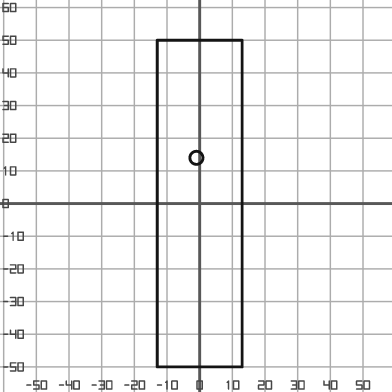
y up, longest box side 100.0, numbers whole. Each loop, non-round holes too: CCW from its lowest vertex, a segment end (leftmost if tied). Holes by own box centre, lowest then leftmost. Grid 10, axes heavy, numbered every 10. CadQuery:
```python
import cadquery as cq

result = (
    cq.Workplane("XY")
    .moveTo(-13.0, -50.0)
    .lineTo(13.0, -50.0)
    .lineTo(13.0, 50.0)
    .lineTo(-13.0, 50.0)
    .close()
    .moveTo(-1.0, 14.0)
    .circle(2.0)
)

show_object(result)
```